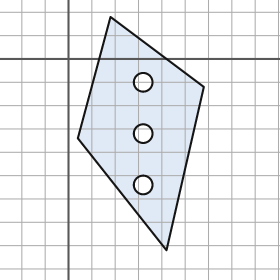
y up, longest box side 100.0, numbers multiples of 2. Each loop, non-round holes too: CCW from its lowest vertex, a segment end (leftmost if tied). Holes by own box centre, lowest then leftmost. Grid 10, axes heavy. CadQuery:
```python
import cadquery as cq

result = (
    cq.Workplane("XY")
    .moveTo(42.0, -82.0)
    .lineTo(58.0, -12.0)
    .lineTo(18.0, 18.0)
    .lineTo(4.0, -34.0)
    .close()
    .moveTo(32.0, -54.0)
    .circle(4.0)
    .moveTo(32.0, -32.0)
    .circle(4.0)
    .moveTo(32.0, -10.0)
    .circle(4.0)
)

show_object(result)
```